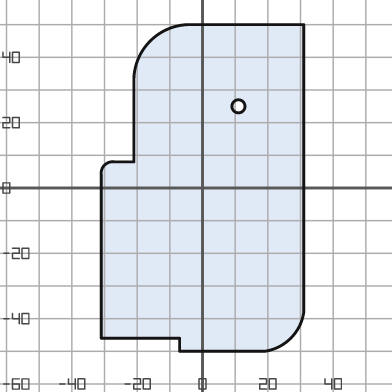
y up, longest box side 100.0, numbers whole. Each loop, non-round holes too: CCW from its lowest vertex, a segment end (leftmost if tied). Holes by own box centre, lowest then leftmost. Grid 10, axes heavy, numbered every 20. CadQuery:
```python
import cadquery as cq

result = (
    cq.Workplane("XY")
    .moveTo(-7.0, -50.0)
    .lineTo(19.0, -50.0)
    .threePointArc((27.0, -46.0), (31.0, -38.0))
    .lineTo(31.0, 50.0)
    .lineTo(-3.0, 50.0)
    .threePointArc((-16.0, 45.0), (-21.0, 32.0))
    .lineTo(-21.0, 8.0)
    .lineTo(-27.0, 8.0)
    .threePointArc((-30.0, 7.0), (-31.0, 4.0))
    .lineTo(-31.0, -46.0)
    .lineTo(-7.0, -46.0)
    .close()
    .moveTo(11.0, 25.0)
    .circle(2.0)
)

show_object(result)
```